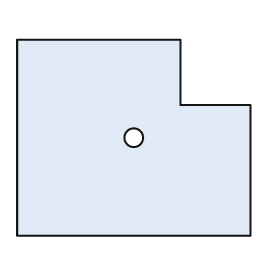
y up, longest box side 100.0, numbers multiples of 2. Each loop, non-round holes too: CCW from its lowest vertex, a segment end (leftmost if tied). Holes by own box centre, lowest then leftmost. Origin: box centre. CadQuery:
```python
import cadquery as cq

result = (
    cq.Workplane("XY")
    .moveTo(-50.0, -42.0)
    .lineTo(50.0, -42.0)
    .lineTo(50.0, 14.0)
    .lineTo(20.0, 14.0)
    .lineTo(20.0, 42.0)
    .lineTo(-50.0, 42.0)
    .close()
    .moveTo(0.0, 0.0)
    .circle(4.0)
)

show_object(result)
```